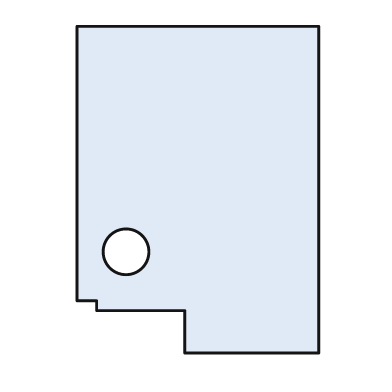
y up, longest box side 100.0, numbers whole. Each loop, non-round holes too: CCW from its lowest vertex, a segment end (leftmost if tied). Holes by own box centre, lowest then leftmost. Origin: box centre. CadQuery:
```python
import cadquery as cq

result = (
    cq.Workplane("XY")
    .moveTo(-4.0, -50.0)
    .lineTo(37.0, -50.0)
    .lineTo(37.0, 50.0)
    .lineTo(-37.0, 50.0)
    .lineTo(-37.0, -34.0)
    .lineTo(-31.0, -34.0)
    .lineTo(-31.0, -37.0)
    .lineTo(-4.0, -37.0)
    .close()
    .moveTo(-22.0, -19.0)
    .circle(7.0)
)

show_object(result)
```